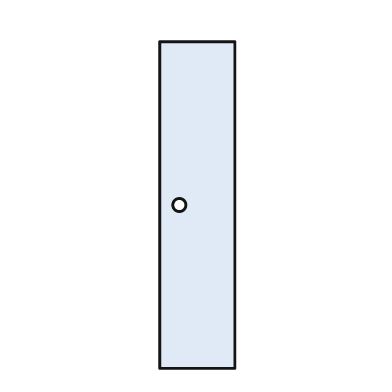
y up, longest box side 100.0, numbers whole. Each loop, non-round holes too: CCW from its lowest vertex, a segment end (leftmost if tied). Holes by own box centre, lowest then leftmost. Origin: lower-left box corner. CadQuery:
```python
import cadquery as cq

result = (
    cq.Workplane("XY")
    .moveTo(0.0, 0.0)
    .lineTo(23.0, 0.0)
    .lineTo(23.0, 100.0)
    .lineTo(0.0, 100.0)
    .close()
    .moveTo(6.0, 50.0)
    .circle(2.0)
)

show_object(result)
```